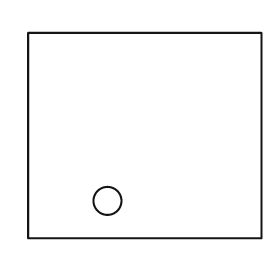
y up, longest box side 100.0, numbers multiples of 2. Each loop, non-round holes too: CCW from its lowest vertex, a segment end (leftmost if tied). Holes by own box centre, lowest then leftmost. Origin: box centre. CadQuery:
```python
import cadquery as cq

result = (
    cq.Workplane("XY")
    .moveTo(-50.0, -44.0)
    .lineTo(50.0, -44.0)
    .lineTo(50.0, 44.0)
    .lineTo(-50.0, 44.0)
    .close()
    .moveTo(-16.0, -28.0)
    .circle(6.0)
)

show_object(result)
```